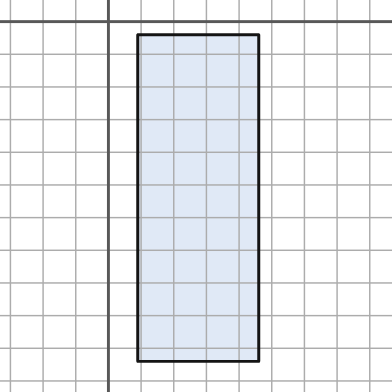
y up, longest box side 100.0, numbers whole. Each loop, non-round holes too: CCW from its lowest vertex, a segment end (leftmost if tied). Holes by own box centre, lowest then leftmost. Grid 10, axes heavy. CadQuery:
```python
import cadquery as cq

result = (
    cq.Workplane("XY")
    .moveTo(9.0, -104.0)
    .lineTo(46.0, -104.0)
    .lineTo(46.0, -4.0)
    .lineTo(9.0, -4.0)
    .close()
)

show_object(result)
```